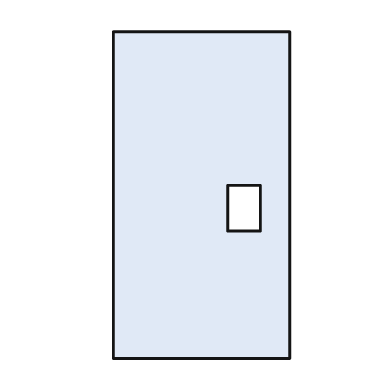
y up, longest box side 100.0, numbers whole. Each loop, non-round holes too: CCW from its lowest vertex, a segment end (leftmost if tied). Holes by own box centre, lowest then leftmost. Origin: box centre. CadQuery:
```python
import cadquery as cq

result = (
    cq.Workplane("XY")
    .moveTo(-27.0, -50.0)
    .lineTo(27.0, -50.0)
    .lineTo(27.0, 50.0)
    .lineTo(-27.0, 50.0)
    .close()
    .moveTo(8.0, -11.0)
    .lineTo(18.0, -11.0)
    .lineTo(18.0, 3.0)
    .lineTo(8.0, 3.0)
    .close()
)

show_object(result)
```